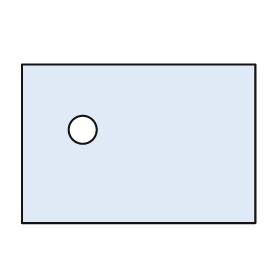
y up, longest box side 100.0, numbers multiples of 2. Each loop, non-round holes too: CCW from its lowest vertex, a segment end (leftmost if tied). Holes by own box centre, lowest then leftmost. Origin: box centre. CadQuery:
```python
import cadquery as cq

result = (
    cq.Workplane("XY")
    .moveTo(-50.0, -34.0)
    .lineTo(50.0, -34.0)
    .lineTo(50.0, 34.0)
    .lineTo(-50.0, 34.0)
    .close()
    .moveTo(-24.0, 6.0)
    .circle(6.0)
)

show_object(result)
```